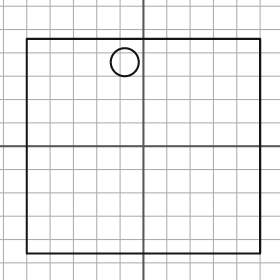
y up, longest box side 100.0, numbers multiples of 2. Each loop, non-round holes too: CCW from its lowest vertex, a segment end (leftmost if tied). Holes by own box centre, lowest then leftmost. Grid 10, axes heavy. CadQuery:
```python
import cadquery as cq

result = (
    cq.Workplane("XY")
    .moveTo(-50.0, -46.0)
    .lineTo(50.0, -46.0)
    .lineTo(50.0, 46.0)
    .lineTo(-50.0, 46.0)
    .close()
    .moveTo(-8.0, 36.0)
    .circle(6.0)
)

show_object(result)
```